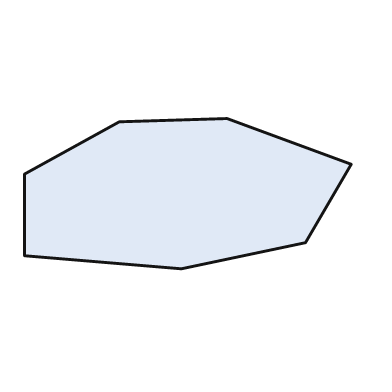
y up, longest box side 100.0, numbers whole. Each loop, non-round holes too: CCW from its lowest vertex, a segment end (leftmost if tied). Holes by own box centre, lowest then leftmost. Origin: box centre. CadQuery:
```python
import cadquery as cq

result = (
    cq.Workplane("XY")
    .moveTo(-2.0, -23.0)
    .lineTo(36.0, -15.0)
    .lineTo(50.0, 9.0)
    .lineTo(12.0, 23.0)
    .lineTo(-21.0, 22.0)
    .lineTo(-50.0, 6.0)
    .lineTo(-50.0, -19.0)
    .close()
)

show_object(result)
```